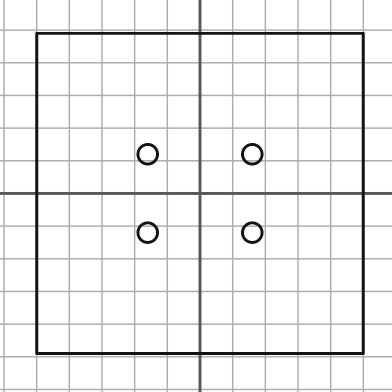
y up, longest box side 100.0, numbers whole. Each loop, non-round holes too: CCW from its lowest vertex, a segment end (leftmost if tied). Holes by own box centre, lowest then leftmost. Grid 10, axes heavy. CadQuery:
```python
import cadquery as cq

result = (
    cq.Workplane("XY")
    .moveTo(-50.0, -49.0)
    .lineTo(50.0, -49.0)
    .lineTo(50.0, 49.0)
    .lineTo(-50.0, 49.0)
    .close()
    .moveTo(-16.0, -12.0)
    .circle(3.0)
    .moveTo(16.0, -12.0)
    .circle(3.0)
    .moveTo(-16.0, 12.0)
    .circle(3.0)
    .moveTo(16.0, 12.0)
    .circle(3.0)
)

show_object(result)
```